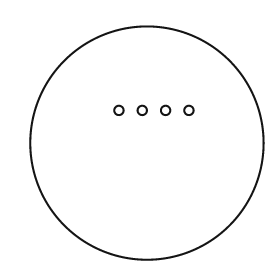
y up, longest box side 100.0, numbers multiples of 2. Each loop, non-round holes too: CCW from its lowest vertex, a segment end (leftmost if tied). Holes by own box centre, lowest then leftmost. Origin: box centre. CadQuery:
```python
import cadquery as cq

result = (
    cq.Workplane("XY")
    .moveTo(0.0, 0.0)
    .circle(50.0)
    .moveTo(-12.0, 14.0)
    .circle(2.0)
    .moveTo(-2.0, 14.0)
    .circle(2.0)
    .moveTo(8.0, 14.0)
    .circle(2.0)
    .moveTo(18.0, 14.0)
    .circle(2.0)
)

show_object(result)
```